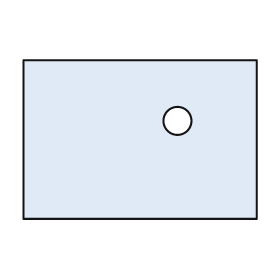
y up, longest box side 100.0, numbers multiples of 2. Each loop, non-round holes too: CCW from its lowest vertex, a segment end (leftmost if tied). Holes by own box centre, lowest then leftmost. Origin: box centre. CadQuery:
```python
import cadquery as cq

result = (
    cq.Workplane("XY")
    .moveTo(-50.0, -34.0)
    .lineTo(50.0, -34.0)
    .lineTo(50.0, 34.0)
    .lineTo(-50.0, 34.0)
    .close()
    .moveTo(16.0, 8.0)
    .circle(6.0)
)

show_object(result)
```